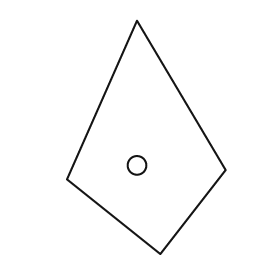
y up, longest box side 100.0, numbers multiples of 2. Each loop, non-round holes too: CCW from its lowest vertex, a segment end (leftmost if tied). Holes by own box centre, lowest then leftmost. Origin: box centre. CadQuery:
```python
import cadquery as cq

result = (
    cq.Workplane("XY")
    .moveTo(6.0, -50.0)
    .lineTo(34.0, -14.0)
    .lineTo(-4.0, 50.0)
    .lineTo(-34.0, -18.0)
    .close()
    .moveTo(-4.0, -12.0)
    .circle(4.0)
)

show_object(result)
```